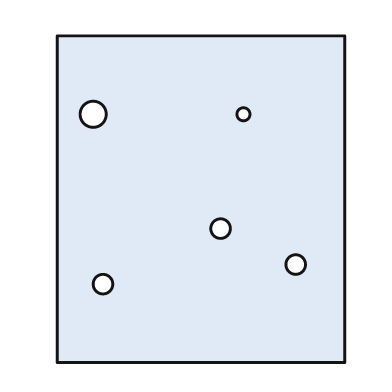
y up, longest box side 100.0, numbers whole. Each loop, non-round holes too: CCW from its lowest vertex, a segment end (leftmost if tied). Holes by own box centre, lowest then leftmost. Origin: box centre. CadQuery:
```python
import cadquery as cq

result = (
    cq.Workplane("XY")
    .moveTo(-44.0, -50.0)
    .lineTo(44.0, -50.0)
    .lineTo(44.0, 50.0)
    .lineTo(-44.0, 50.0)
    .close()
    .moveTo(-30.0, -26.0)
    .circle(3.0)
    .moveTo(29.0, -20.0)
    .circle(3.0)
    .moveTo(6.0, -9.0)
    .circle(3.0)
    .moveTo(-33.0, 26.0)
    .circle(4.0)
    .moveTo(13.0, 26.0)
    .circle(2.0)
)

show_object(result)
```